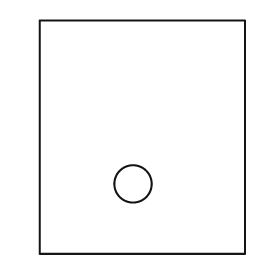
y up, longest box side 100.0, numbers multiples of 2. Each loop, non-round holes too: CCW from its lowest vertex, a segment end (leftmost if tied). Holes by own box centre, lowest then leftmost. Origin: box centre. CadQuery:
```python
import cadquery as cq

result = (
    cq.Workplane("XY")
    .moveTo(-44.0, -50.0)
    .lineTo(44.0, -50.0)
    .lineTo(44.0, 50.0)
    .lineTo(-44.0, 50.0)
    .close()
    .moveTo(-4.0, -20.0)
    .circle(8.0)
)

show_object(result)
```